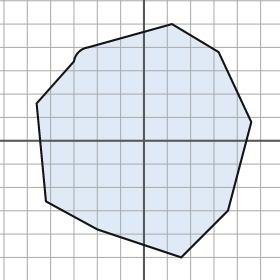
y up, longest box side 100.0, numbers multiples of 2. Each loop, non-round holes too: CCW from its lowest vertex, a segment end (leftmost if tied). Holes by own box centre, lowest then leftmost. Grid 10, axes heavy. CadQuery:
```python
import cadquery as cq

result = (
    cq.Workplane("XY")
    .moveTo(16.0, -50.0)
    .lineTo(36.0, -30.0)
    .lineTo(46.0, 8.0)
    .lineTo(32.0, 38.0)
    .lineTo(12.0, 50.0)
    .lineTo(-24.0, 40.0)
    .threePointArc((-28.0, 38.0), (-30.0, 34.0))
    .lineTo(-46.0, 16.0)
    .lineTo(-42.0, -26.0)
    .lineTo(-20.0, -38.0)
    .close()
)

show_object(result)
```